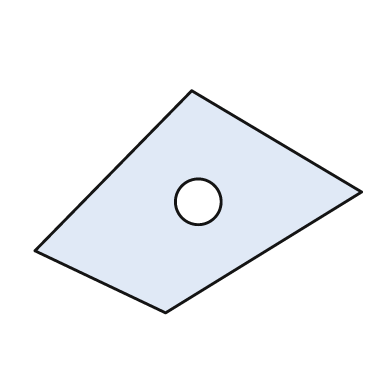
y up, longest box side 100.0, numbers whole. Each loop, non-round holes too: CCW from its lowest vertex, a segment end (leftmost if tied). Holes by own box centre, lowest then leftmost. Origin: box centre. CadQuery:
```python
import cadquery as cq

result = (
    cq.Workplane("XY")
    .moveTo(-10.0, -34.0)
    .lineTo(50.0, 3.0)
    .lineTo(-2.0, 34.0)
    .lineTo(-50.0, -15.0)
    .close()
    .moveTo(0.0, 0.0)
    .circle(7.0)
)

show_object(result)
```